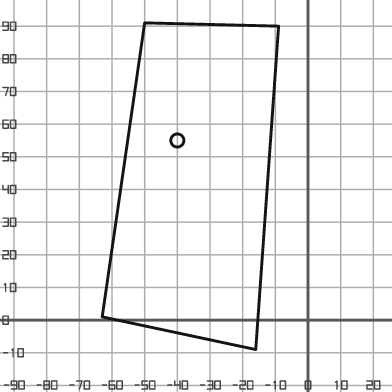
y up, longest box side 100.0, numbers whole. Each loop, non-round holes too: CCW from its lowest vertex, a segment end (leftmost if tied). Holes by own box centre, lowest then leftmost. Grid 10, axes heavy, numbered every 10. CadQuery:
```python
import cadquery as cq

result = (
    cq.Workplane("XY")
    .moveTo(-16.0, -9.0)
    .lineTo(-9.0, 90.0)
    .lineTo(-50.0, 91.0)
    .lineTo(-63.0, 1.0)
    .close()
    .moveTo(-40.0, 55.0)
    .circle(2.0)
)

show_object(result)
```